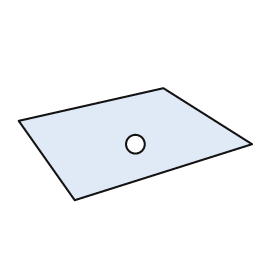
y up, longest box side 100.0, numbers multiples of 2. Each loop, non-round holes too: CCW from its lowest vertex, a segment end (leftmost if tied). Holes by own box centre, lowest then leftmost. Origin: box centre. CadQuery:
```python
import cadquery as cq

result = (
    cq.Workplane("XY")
    .moveTo(-26.0, -24.0)
    .lineTo(50.0, 0.0)
    .lineTo(12.0, 24.0)
    .lineTo(-50.0, 10.0)
    .close()
    .moveTo(0.0, 0.0)
    .circle(4.0)
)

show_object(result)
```